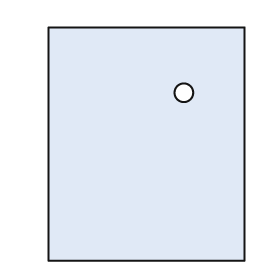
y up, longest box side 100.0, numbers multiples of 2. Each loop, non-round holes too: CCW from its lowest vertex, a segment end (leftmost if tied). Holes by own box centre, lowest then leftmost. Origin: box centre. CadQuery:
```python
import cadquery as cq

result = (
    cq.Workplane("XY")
    .moveTo(-42.0, -50.0)
    .lineTo(42.0, -50.0)
    .lineTo(42.0, 50.0)
    .lineTo(-42.0, 50.0)
    .close()
    .moveTo(16.0, 22.0)
    .circle(4.0)
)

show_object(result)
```